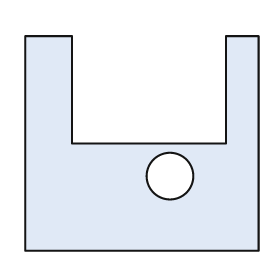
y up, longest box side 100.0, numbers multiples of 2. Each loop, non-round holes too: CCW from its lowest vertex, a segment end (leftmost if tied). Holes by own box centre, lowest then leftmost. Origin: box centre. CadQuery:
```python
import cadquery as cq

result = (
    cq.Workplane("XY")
    .moveTo(-50.0, -46.0)
    .lineTo(50.0, -46.0)
    .lineTo(50.0, 46.0)
    .lineTo(36.0, 46.0)
    .lineTo(36.0, 0.0)
    .lineTo(-30.0, 0.0)
    .lineTo(-30.0, 46.0)
    .lineTo(-50.0, 46.0)
    .close()
    .moveTo(12.0, -14.0)
    .circle(10.0)
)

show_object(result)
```